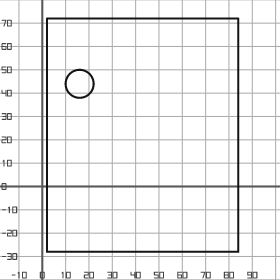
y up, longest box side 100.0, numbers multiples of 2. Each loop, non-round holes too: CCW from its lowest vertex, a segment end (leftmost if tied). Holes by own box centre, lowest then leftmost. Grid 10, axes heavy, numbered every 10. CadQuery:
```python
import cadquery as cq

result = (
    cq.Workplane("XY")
    .moveTo(2.0, -28.0)
    .lineTo(84.0, -28.0)
    .lineTo(84.0, 72.0)
    .lineTo(2.0, 72.0)
    .close()
    .moveTo(16.0, 44.0)
    .circle(6.0)
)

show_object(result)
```